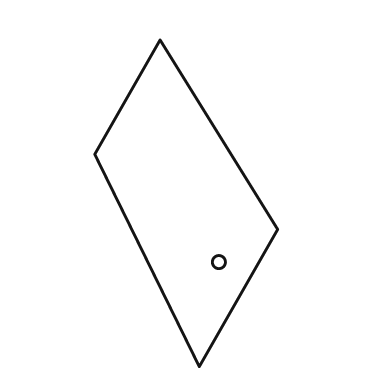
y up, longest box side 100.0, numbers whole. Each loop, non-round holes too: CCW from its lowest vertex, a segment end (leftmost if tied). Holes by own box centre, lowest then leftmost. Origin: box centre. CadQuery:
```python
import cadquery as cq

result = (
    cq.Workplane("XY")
    .moveTo(4.0, -50.0)
    .lineTo(28.0, -8.0)
    .lineTo(-8.0, 50.0)
    .lineTo(-28.0, 15.0)
    .close()
    .moveTo(10.0, -18.0)
    .circle(2.0)
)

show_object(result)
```